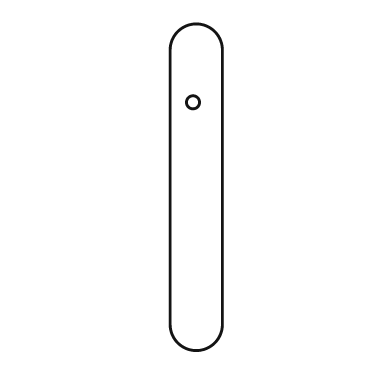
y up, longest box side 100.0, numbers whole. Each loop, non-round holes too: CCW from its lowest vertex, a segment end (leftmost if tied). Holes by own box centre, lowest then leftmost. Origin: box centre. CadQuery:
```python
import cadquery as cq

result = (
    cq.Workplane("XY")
    .moveTo(-8.0, -42.0)
    .threePointArc((0.0, -50.0), (8.0, -42.0))
    .lineTo(8.0, 42.0)
    .threePointArc((0.0, 50.0), (-8.0, 42.0))
    .close()
    .moveTo(-1.0, 26.0)
    .circle(2.0)
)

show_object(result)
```